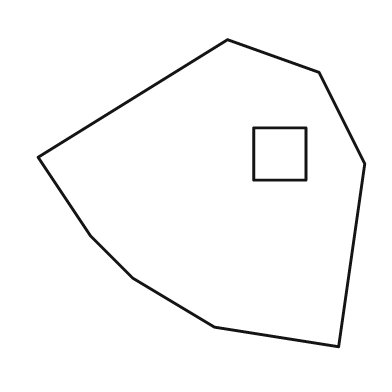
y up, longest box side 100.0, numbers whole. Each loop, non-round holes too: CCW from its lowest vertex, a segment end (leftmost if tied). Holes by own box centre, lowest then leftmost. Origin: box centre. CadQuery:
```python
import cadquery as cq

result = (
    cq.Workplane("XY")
    .moveTo(42.0, -47.0)
    .lineTo(50.0, 9.0)
    .lineTo(36.0, 37.0)
    .lineTo(8.0, 47.0)
    .lineTo(-50.0, 11.0)
    .lineTo(-34.0, -13.0)
    .lineTo(-21.0, -26.0)
    .lineTo(4.0, -41.0)
    .close()
    .moveTo(16.0, 4.0)
    .lineTo(32.0, 4.0)
    .lineTo(32.0, 20.0)
    .lineTo(16.0, 20.0)
    .close()
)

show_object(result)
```